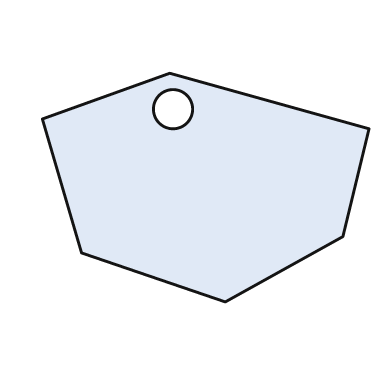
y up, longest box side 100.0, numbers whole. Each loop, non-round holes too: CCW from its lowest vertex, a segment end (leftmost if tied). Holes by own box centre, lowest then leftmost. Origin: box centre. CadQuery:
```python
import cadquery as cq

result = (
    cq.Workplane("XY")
    .moveTo(6.0, -35.0)
    .lineTo(42.0, -15.0)
    .lineTo(50.0, 18.0)
    .lineTo(-11.0, 35.0)
    .lineTo(-50.0, 21.0)
    .lineTo(-38.0, -20.0)
    .close()
    .moveTo(-10.0, 24.0)
    .circle(6.0)
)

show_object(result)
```